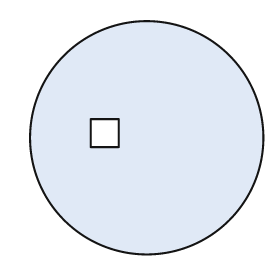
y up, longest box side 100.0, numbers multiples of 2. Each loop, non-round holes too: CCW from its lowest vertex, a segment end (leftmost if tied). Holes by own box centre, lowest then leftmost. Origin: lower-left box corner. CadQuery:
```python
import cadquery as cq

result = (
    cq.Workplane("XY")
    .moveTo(50.0, 50.0)
    .circle(50.0)
    .moveTo(26.0, 46.0)
    .lineTo(38.0, 46.0)
    .lineTo(38.0, 58.0)
    .lineTo(26.0, 58.0)
    .close()
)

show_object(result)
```